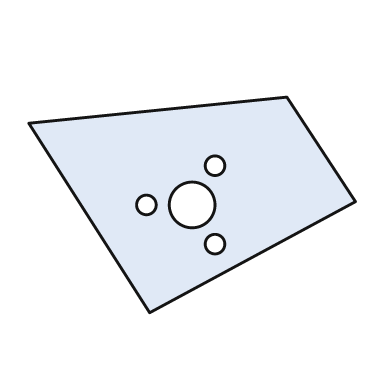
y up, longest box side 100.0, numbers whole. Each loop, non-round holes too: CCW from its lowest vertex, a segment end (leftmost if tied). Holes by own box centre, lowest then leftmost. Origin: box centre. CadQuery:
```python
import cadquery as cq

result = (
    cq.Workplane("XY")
    .moveTo(-13.0, -33.0)
    .lineTo(50.0, 1.0)
    .lineTo(29.0, 33.0)
    .lineTo(-50.0, 25.0)
    .close()
    .moveTo(7.0, -12.0)
    .circle(3.0)
    .moveTo(-14.0, 0.0)
    .circle(3.0)
    .moveTo(0.0, 0.0)
    .circle(7.0)
    .moveTo(7.0, 12.0)
    .circle(3.0)
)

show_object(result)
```